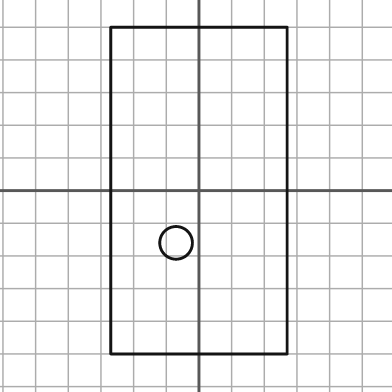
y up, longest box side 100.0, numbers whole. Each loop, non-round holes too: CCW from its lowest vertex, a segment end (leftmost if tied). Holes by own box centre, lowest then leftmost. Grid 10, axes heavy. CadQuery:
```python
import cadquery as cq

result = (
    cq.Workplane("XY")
    .moveTo(-27.0, -50.0)
    .lineTo(27.0, -50.0)
    .lineTo(27.0, 50.0)
    .lineTo(-27.0, 50.0)
    .close()
    .moveTo(-7.0, -16.0)
    .circle(5.0)
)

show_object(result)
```